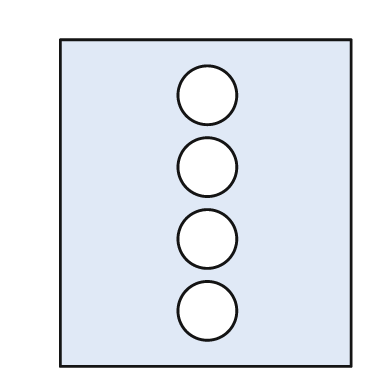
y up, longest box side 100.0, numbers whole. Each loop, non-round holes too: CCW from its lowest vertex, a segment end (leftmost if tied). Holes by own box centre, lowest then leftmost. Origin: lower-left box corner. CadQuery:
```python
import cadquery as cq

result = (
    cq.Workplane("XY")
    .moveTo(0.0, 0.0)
    .lineTo(89.0, 0.0)
    .lineTo(89.0, 100.0)
    .lineTo(0.0, 100.0)
    .close()
    .moveTo(45.0, 17.0)
    .circle(9.0)
    .moveTo(45.0, 39.0)
    .circle(9.0)
    .moveTo(45.0, 61.0)
    .circle(9.0)
    .moveTo(45.0, 83.0)
    .circle(9.0)
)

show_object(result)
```